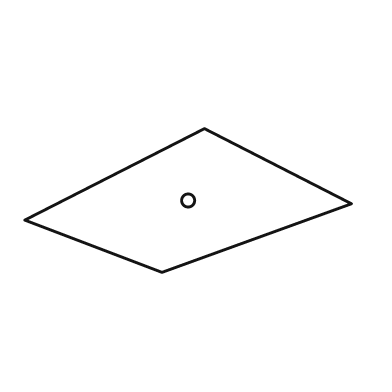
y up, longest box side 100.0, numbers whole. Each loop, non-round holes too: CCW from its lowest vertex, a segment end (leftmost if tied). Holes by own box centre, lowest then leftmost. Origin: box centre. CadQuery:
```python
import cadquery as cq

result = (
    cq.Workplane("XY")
    .moveTo(-8.0, -22.0)
    .lineTo(50.0, -1.0)
    .lineTo(5.0, 22.0)
    .lineTo(-50.0, -6.0)
    .close()
    .moveTo(0.0, 0.0)
    .circle(2.0)
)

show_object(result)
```